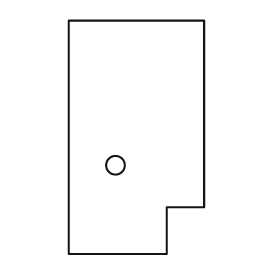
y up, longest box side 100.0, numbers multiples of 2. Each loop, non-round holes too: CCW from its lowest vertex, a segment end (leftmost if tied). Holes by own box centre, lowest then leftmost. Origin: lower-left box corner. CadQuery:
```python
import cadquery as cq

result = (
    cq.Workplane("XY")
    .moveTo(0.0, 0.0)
    .lineTo(42.0, 0.0)
    .lineTo(42.0, 20.0)
    .lineTo(58.0, 20.0)
    .lineTo(58.0, 100.0)
    .lineTo(0.0, 100.0)
    .close()
    .moveTo(20.0, 38.0)
    .circle(4.0)
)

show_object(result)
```